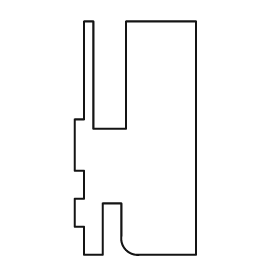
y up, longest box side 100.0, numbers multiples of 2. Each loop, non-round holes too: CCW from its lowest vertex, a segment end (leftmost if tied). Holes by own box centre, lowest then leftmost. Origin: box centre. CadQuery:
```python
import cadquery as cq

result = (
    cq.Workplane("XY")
    .moveTo(-22.0, -50.0)
    .lineTo(-14.0, -50.0)
    .lineTo(-14.0, -28.0)
    .lineTo(-6.0, -28.0)
    .lineTo(-6.0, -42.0)
    .threePointArc((-4.0, -48.0), (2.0, -50.0))
    .lineTo(26.0, -50.0)
    .lineTo(26.0, 50.0)
    .lineTo(-4.0, 50.0)
    .lineTo(-4.0, 4.0)
    .lineTo(-18.0, 4.0)
    .lineTo(-18.0, 50.0)
    .lineTo(-22.0, 50.0)
    .lineTo(-22.0, 8.0)
    .lineTo(-26.0, 8.0)
    .lineTo(-26.0, -14.0)
    .lineTo(-22.0, -14.0)
    .lineTo(-22.0, -26.0)
    .lineTo(-26.0, -26.0)
    .lineTo(-26.0, -38.0)
    .lineTo(-22.0, -38.0)
    .close()
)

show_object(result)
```